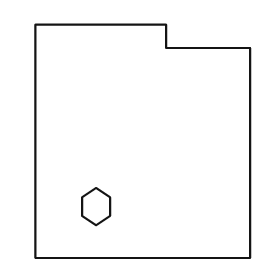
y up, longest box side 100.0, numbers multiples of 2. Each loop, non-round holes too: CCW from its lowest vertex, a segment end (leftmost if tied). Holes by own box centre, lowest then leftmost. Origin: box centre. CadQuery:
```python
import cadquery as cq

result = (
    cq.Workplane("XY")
    .moveTo(-46.0, -50.0)
    .lineTo(46.0, -50.0)
    .lineTo(46.0, 40.0)
    .lineTo(10.0, 40.0)
    .lineTo(10.0, 50.0)
    .lineTo(-46.0, 50.0)
    .close()
    .moveTo(-20.0, -36.0)
    .lineTo(-14.0, -32.0)
    .lineTo(-14.0, -24.0)
    .lineTo(-20.0, -20.0)
    .lineTo(-26.0, -24.0)
    .lineTo(-26.0, -32.0)
    .close()
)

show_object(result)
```